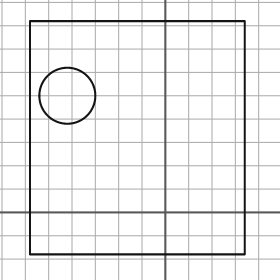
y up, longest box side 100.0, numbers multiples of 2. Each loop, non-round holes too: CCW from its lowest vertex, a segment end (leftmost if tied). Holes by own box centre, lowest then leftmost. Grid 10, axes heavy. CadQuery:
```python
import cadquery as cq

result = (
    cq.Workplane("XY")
    .moveTo(-58.0, -18.0)
    .lineTo(34.0, -18.0)
    .lineTo(34.0, 82.0)
    .lineTo(-58.0, 82.0)
    .close()
    .moveTo(-42.0, 50.0)
    .circle(12.0)
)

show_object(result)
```